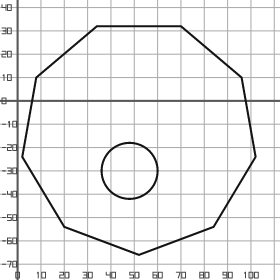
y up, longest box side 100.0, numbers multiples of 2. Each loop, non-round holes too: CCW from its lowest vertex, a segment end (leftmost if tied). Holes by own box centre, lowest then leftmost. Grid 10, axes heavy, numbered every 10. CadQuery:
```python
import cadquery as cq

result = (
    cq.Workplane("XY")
    .moveTo(52.0, -66.0)
    .lineTo(84.0, -54.0)
    .lineTo(102.0, -24.0)
    .lineTo(96.0, 10.0)
    .lineTo(70.0, 32.0)
    .lineTo(34.0, 32.0)
    .lineTo(8.0, 10.0)
    .lineTo(2.0, -24.0)
    .lineTo(20.0, -54.0)
    .close()
    .moveTo(48.0, -30.0)
    .circle(12.0)
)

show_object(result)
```